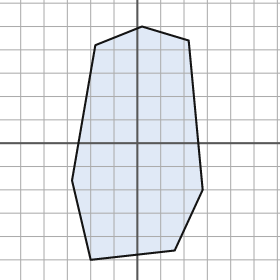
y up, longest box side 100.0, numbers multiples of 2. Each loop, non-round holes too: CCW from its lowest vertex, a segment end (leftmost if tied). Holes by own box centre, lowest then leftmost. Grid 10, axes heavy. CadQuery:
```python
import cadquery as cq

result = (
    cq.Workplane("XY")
    .moveTo(-20.0, -50.0)
    .lineTo(16.0, -46.0)
    .lineTo(28.0, -20.0)
    .lineTo(22.0, 44.0)
    .lineTo(2.0, 50.0)
    .lineTo(-18.0, 42.0)
    .lineTo(-28.0, -16.0)
    .close()
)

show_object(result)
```